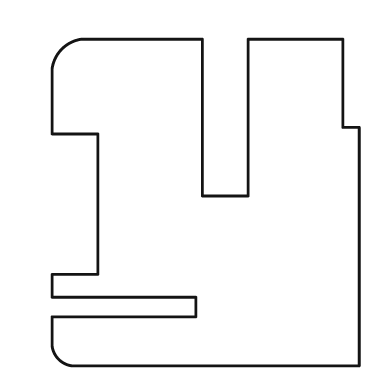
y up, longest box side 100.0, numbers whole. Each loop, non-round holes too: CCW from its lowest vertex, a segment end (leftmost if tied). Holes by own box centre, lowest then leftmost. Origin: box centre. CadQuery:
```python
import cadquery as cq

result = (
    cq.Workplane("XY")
    .moveTo(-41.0, -50.0)
    .lineTo(47.0, -50.0)
    .lineTo(47.0, 23.0)
    .lineTo(42.0, 23.0)
    .lineTo(42.0, 50.0)
    .lineTo(13.0, 50.0)
    .lineTo(13.0, 2.0)
    .lineTo(-1.0, 2.0)
    .lineTo(-1.0, 50.0)
    .lineTo(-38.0, 50.0)
    .threePointArc((-44.0, 47.0), (-47.0, 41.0))
    .lineTo(-47.0, 21.0)
    .lineTo(-33.0, 21.0)
    .lineTo(-33.0, -22.0)
    .lineTo(-47.0, -22.0)
    .lineTo(-47.0, -29.0)
    .lineTo(-3.0, -29.0)
    .lineTo(-3.0, -35.0)
    .lineTo(-47.0, -35.0)
    .lineTo(-47.0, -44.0)
    .threePointArc((-45.0, -48.0), (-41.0, -50.0))
    .close()
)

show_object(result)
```